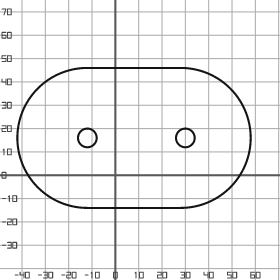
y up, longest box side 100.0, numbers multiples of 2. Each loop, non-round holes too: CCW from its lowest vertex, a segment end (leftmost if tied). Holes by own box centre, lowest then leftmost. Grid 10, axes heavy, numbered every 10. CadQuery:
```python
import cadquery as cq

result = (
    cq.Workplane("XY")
    .moveTo(-12.0, -14.0)
    .lineTo(28.0, -14.0)
    .threePointArc((58.0, 16.0), (28.0, 46.0))
    .lineTo(-12.0, 46.0)
    .threePointArc((-42.0, 16.0), (-12.0, -14.0))
    .close()
    .moveTo(-12.0, 16.0)
    .circle(4.0)
    .moveTo(30.0, 16.0)
    .circle(4.0)
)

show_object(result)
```